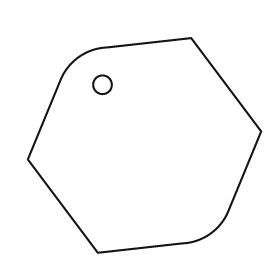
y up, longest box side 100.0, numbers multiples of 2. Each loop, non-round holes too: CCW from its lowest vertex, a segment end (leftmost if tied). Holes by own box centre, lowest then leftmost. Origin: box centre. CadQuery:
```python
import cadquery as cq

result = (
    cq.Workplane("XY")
    .moveTo(-20.0, -46.0)
    .lineTo(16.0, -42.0)
    .threePointArc((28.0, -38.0), (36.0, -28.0))
    .lineTo(50.0, 6.0)
    .lineTo(20.0, 46.0)
    .lineTo(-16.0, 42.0)
    .threePointArc((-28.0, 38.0), (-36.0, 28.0))
    .lineTo(-50.0, -6.0)
    .close()
    .moveTo(-18.0, 26.0)
    .circle(4.0)
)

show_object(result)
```